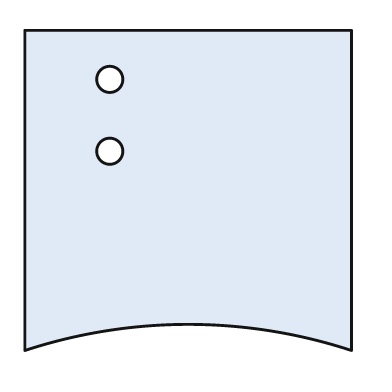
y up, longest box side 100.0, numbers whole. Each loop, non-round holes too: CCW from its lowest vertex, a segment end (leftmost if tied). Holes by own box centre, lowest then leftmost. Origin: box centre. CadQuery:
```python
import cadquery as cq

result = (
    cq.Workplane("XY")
    .moveTo(-50.0, -49.0)
    .threePointArc((0.0, -41.0), (50.0, -49.0))
    .lineTo(50.0, 49.0)
    .lineTo(-50.0, 49.0)
    .close()
    .moveTo(-24.0, 12.0)
    .circle(4.0)
    .moveTo(-24.0, 34.0)
    .circle(4.0)
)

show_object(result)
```